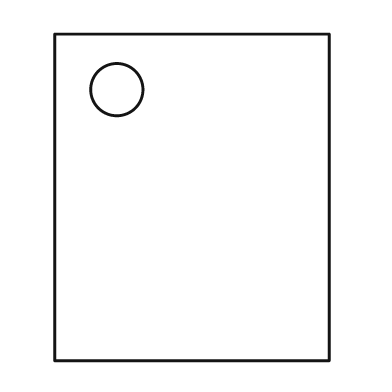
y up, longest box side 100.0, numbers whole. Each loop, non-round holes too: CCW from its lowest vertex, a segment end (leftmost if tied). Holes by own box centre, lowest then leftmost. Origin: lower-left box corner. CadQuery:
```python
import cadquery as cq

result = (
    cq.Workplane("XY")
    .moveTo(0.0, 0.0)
    .lineTo(84.0, 0.0)
    .lineTo(84.0, 100.0)
    .lineTo(0.0, 100.0)
    .close()
    .moveTo(19.0, 83.0)
    .circle(8.0)
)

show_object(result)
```